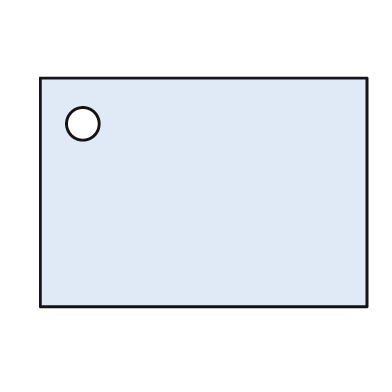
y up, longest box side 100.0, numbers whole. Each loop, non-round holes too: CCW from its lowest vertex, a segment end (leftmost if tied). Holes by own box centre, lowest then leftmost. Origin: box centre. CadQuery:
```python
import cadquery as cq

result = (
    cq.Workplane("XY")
    .moveTo(-50.0, -35.0)
    .lineTo(50.0, -35.0)
    .lineTo(50.0, 35.0)
    .lineTo(-50.0, 35.0)
    .close()
    .moveTo(-37.0, 21.0)
    .circle(5.0)
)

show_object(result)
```